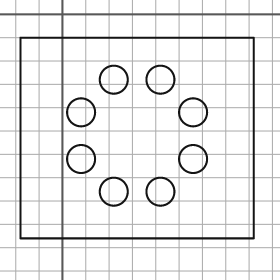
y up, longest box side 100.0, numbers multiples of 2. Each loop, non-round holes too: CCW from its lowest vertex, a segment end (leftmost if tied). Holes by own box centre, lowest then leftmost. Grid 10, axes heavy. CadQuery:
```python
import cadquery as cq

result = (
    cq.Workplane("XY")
    .moveTo(-18.0, -96.0)
    .lineTo(82.0, -96.0)
    .lineTo(82.0, -10.0)
    .lineTo(-18.0, -10.0)
    .close()
    .moveTo(22.0, -76.0)
    .circle(6.0)
    .moveTo(42.0, -76.0)
    .circle(6.0)
    .moveTo(8.0, -62.0)
    .circle(6.0)
    .moveTo(56.0, -62.0)
    .circle(6.0)
    .moveTo(8.0, -42.0)
    .circle(6.0)
    .moveTo(56.0, -42.0)
    .circle(6.0)
    .moveTo(22.0, -28.0)
    .circle(6.0)
    .moveTo(42.0, -28.0)
    .circle(6.0)
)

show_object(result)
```